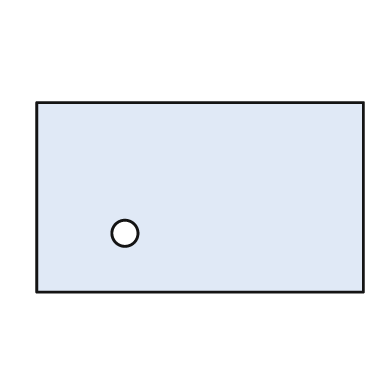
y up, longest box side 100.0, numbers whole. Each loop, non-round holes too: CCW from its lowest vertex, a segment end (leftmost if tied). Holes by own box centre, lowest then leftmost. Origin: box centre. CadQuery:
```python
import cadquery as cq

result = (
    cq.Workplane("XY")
    .moveTo(-50.0, -29.0)
    .lineTo(50.0, -29.0)
    .lineTo(50.0, 29.0)
    .lineTo(-50.0, 29.0)
    .close()
    .moveTo(-23.0, -11.0)
    .circle(4.0)
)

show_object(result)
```